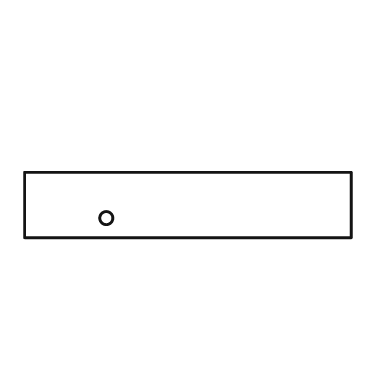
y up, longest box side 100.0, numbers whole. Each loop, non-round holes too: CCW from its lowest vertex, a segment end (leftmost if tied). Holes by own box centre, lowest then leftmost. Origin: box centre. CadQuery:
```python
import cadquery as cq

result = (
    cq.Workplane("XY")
    .moveTo(-50.0, -10.0)
    .lineTo(50.0, -10.0)
    .lineTo(50.0, 10.0)
    .lineTo(-50.0, 10.0)
    .close()
    .moveTo(-25.0, -4.0)
    .circle(2.0)
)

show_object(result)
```